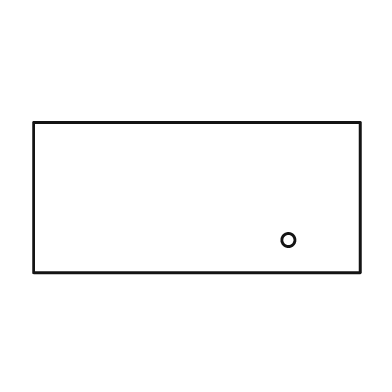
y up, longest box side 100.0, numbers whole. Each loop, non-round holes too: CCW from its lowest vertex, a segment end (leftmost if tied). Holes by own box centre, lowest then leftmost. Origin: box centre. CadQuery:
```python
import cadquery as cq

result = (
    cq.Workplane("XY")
    .moveTo(-50.0, -23.0)
    .lineTo(50.0, -23.0)
    .lineTo(50.0, 23.0)
    .lineTo(-50.0, 23.0)
    .close()
    .moveTo(28.0, -13.0)
    .circle(2.0)
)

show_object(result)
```